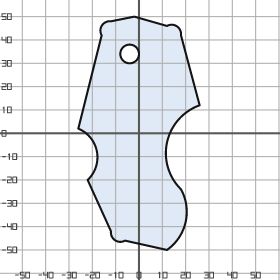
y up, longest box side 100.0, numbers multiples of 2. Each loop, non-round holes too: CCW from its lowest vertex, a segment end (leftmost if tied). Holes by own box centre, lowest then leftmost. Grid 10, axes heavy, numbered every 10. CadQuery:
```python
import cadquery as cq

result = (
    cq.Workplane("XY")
    .moveTo(12.0, -50.0)
    .threePointArc((20.0, -38.0), (18.0, -24.0))
    .threePointArc((12.0, -4.0), (26.0, 12.0))
    .lineTo(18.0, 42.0)
    .threePointArc((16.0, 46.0), (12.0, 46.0))
    .lineTo(-2.0, 50.0)
    .lineTo(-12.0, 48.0)
    .threePointArc((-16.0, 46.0), (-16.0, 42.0))
    .lineTo(-26.0, 2.0)
    .threePointArc((-18.0, -8.0), (-22.0, -20.0))
    .lineTo(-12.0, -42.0)
    .threePointArc((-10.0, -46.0), (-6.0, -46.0))
    .close()
    .moveTo(-4.0, 34.0)
    .circle(4.0)
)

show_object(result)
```